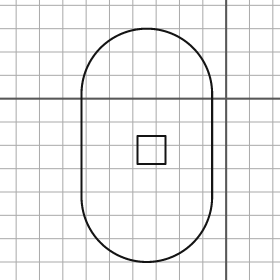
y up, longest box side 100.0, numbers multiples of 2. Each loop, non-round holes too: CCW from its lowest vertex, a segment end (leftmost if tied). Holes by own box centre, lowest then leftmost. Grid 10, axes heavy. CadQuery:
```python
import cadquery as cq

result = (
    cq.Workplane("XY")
    .moveTo(-62.0, -42.0)
    .threePointArc((-34.0, -70.0), (-6.0, -42.0))
    .lineTo(-6.0, 2.0)
    .threePointArc((-34.0, 30.0), (-62.0, 2.0))
    .close()
    .moveTo(-38.0, -28.0)
    .lineTo(-26.0, -28.0)
    .lineTo(-26.0, -16.0)
    .lineTo(-38.0, -16.0)
    .close()
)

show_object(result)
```